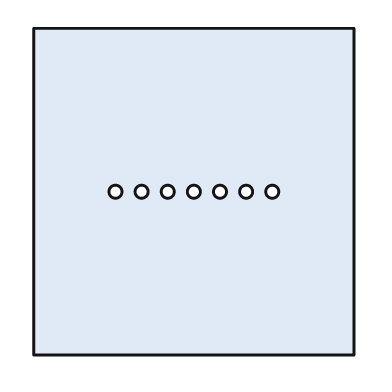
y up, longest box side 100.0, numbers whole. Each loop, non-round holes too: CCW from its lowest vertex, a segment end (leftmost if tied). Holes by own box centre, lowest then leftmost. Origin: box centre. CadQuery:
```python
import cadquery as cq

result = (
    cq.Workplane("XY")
    .moveTo(-49.0, -50.0)
    .lineTo(49.0, -50.0)
    .lineTo(49.0, 50.0)
    .lineTo(-49.0, 50.0)
    .close()
    .moveTo(-24.0, 0.0)
    .circle(2.0)
    .moveTo(-16.0, 0.0)
    .circle(2.0)
    .moveTo(-8.0, 0.0)
    .circle(2.0)
    .moveTo(0.0, 0.0)
    .circle(2.0)
    .moveTo(8.0, 0.0)
    .circle(2.0)
    .moveTo(16.0, 0.0)
    .circle(2.0)
    .moveTo(24.0, 0.0)
    .circle(2.0)
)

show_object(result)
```